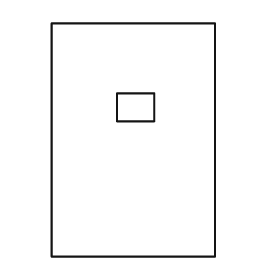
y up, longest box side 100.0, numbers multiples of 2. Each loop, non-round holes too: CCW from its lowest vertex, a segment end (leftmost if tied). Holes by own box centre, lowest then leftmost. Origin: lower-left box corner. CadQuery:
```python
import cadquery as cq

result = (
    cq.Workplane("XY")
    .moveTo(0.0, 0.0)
    .lineTo(70.0, 0.0)
    .lineTo(70.0, 100.0)
    .lineTo(0.0, 100.0)
    .close()
    .moveTo(28.0, 58.0)
    .lineTo(44.0, 58.0)
    .lineTo(44.0, 70.0)
    .lineTo(28.0, 70.0)
    .close()
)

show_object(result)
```